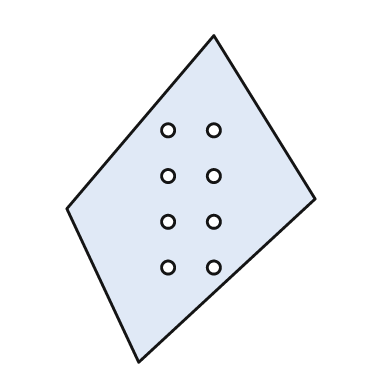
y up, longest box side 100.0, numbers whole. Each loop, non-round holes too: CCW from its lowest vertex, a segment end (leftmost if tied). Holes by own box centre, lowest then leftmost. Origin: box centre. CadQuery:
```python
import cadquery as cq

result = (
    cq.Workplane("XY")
    .moveTo(-16.0, -50.0)
    .lineTo(38.0, 0.0)
    .lineTo(7.0, 50.0)
    .lineTo(-38.0, -3.0)
    .close()
    .moveTo(-7.0, -21.0)
    .circle(2.0)
    .moveTo(7.0, -21.0)
    .circle(2.0)
    .moveTo(-7.0, -7.0)
    .circle(2.0)
    .moveTo(7.0, -7.0)
    .circle(2.0)
    .moveTo(-7.0, 7.0)
    .circle(2.0)
    .moveTo(7.0, 7.0)
    .circle(2.0)
    .moveTo(-7.0, 21.0)
    .circle(2.0)
    .moveTo(7.0, 21.0)
    .circle(2.0)
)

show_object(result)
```